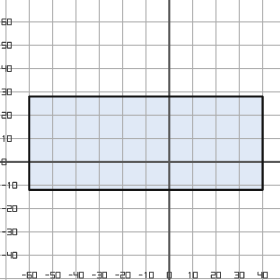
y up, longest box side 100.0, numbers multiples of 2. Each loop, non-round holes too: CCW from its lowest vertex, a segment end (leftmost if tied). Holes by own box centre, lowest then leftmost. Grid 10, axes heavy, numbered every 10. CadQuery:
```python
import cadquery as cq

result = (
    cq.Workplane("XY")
    .moveTo(-60.0, -12.0)
    .lineTo(40.0, -12.0)
    .lineTo(40.0, 28.0)
    .lineTo(-60.0, 28.0)
    .close()
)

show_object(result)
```